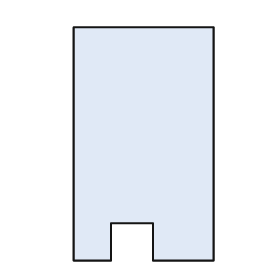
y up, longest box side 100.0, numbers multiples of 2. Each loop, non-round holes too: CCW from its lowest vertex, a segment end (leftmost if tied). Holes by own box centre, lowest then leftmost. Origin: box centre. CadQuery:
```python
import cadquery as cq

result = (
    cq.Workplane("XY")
    .moveTo(-30.0, -50.0)
    .lineTo(-14.0, -50.0)
    .lineTo(-14.0, -34.0)
    .lineTo(4.0, -34.0)
    .lineTo(4.0, -50.0)
    .lineTo(30.0, -50.0)
    .lineTo(30.0, 50.0)
    .lineTo(-30.0, 50.0)
    .close()
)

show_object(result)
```